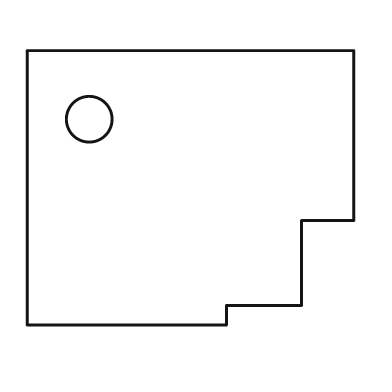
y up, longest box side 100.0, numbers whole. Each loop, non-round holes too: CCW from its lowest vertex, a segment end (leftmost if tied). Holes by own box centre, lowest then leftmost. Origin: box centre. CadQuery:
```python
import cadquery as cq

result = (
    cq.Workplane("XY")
    .moveTo(-50.0, -42.0)
    .lineTo(11.0, -42.0)
    .lineTo(11.0, -36.0)
    .lineTo(34.0, -36.0)
    .lineTo(34.0, -10.0)
    .lineTo(50.0, -10.0)
    .lineTo(50.0, 42.0)
    .lineTo(-50.0, 42.0)
    .close()
    .moveTo(-31.0, 21.0)
    .circle(7.0)
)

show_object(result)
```